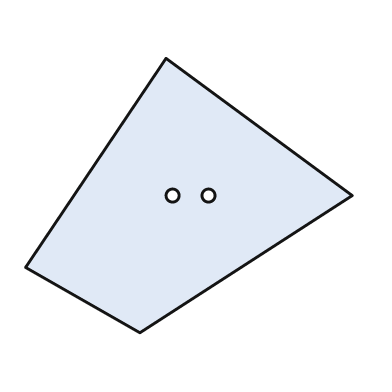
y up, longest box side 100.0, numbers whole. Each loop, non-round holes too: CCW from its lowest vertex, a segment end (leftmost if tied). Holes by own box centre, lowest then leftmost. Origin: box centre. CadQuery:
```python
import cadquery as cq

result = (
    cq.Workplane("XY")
    .moveTo(-15.0, -42.0)
    .lineTo(50.0, 0.0)
    .lineTo(-7.0, 42.0)
    .lineTo(-50.0, -22.0)
    .close()
    .moveTo(-5.0, 0.0)
    .circle(2.0)
    .moveTo(6.0, 0.0)
    .circle(2.0)
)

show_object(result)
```